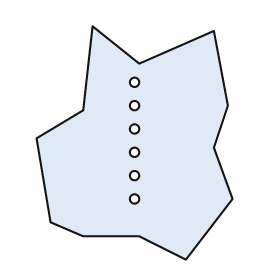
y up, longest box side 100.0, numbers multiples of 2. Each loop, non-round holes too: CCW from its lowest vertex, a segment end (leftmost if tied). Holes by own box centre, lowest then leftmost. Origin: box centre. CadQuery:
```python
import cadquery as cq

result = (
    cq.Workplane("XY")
    .moveTo(22.0, -50.0)
    .lineTo(42.0, -24.0)
    .lineTo(34.0, -2.0)
    .lineTo(40.0, 16.0)
    .lineTo(34.0, 48.0)
    .lineTo(2.0, 34.0)
    .lineTo(-18.0, 50.0)
    .lineTo(-22.0, 14.0)
    .lineTo(-42.0, 2.0)
    .lineTo(-36.0, -34.0)
    .lineTo(-22.0, -40.0)
    .lineTo(2.0, -40.0)
    .close()
    .moveTo(0.0, -24.0)
    .circle(2.0)
    .moveTo(0.0, -14.0)
    .circle(2.0)
    .moveTo(0.0, -4.0)
    .circle(2.0)
    .moveTo(0.0, 6.0)
    .circle(2.0)
    .moveTo(0.0, 16.0)
    .circle(2.0)
    .moveTo(0.0, 26.0)
    .circle(2.0)
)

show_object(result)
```